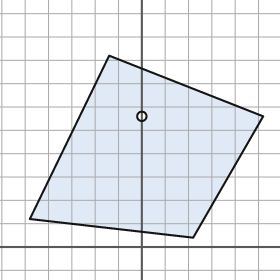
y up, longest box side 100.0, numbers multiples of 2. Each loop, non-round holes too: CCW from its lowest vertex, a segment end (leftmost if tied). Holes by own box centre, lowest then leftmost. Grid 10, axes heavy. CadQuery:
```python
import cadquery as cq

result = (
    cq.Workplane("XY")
    .moveTo(22.0, 4.0)
    .lineTo(52.0, 56.0)
    .lineTo(-14.0, 82.0)
    .lineTo(-48.0, 12.0)
    .close()
    .moveTo(0.0, 56.0)
    .circle(2.0)
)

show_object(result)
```